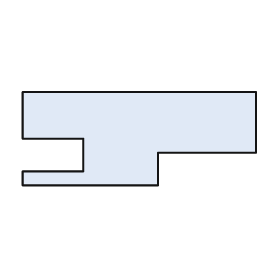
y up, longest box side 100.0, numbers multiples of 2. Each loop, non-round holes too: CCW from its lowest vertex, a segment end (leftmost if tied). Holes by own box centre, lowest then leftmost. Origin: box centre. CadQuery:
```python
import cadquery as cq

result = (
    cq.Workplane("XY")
    .moveTo(-50.0, -20.0)
    .lineTo(8.0, -20.0)
    .lineTo(8.0, -6.0)
    .lineTo(50.0, -6.0)
    .lineTo(50.0, 20.0)
    .lineTo(-50.0, 20.0)
    .lineTo(-50.0, 0.0)
    .lineTo(-24.0, 0.0)
    .lineTo(-24.0, -14.0)
    .lineTo(-50.0, -14.0)
    .close()
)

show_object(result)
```